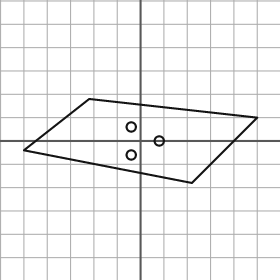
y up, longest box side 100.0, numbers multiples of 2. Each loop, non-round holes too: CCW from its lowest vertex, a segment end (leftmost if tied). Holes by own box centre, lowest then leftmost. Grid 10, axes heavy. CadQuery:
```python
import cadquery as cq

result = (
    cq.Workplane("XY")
    .moveTo(22.0, -18.0)
    .lineTo(50.0, 10.0)
    .lineTo(-22.0, 18.0)
    .lineTo(-50.0, -4.0)
    .close()
    .moveTo(-4.0, -6.0)
    .circle(2.0)
    .moveTo(8.0, 0.0)
    .circle(2.0)
    .moveTo(-4.0, 6.0)
    .circle(2.0)
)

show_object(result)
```